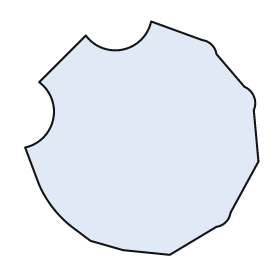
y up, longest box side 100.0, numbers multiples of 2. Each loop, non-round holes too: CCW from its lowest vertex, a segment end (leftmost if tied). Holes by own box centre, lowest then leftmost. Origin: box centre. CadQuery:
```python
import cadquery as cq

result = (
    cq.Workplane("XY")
    .moveTo(12.0, -50.0)
    .lineTo(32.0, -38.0)
    .threePointArc((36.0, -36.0), (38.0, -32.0))
    .lineTo(50.0, -10.0)
    .lineTo(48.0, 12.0)
    .threePointArc((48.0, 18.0), (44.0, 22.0))
    .lineTo(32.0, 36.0)
    .threePointArc((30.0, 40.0), (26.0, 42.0))
    .lineTo(4.0, 50.0)
    .threePointArc((-8.0, 38.0), (-24.0, 44.0))
    .lineTo(-44.0, 24.0)
    .threePointArc((-38.0, 8.0), (-50.0, -4.0))
    .lineTo(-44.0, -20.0)
    .threePointArc((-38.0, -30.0), (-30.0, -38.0))
    .lineTo(-22.0, -44.0)
    .lineTo(-8.0, -48.0)
    .close()
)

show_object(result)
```